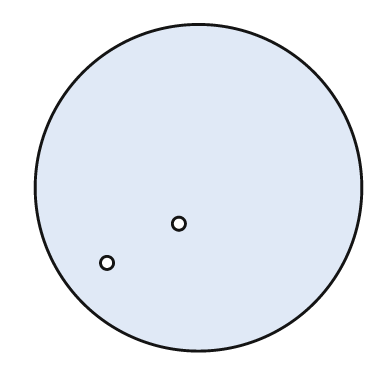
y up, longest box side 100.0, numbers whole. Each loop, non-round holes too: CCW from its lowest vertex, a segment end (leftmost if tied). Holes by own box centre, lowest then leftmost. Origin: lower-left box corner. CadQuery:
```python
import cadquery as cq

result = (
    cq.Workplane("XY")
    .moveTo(50.0, 50.0)
    .circle(50.0)
    .moveTo(22.0, 27.0)
    .circle(2.0)
    .moveTo(44.0, 39.0)
    .circle(2.0)
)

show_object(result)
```